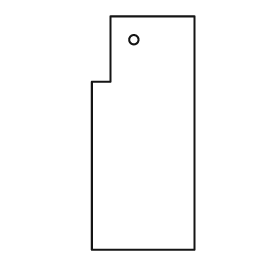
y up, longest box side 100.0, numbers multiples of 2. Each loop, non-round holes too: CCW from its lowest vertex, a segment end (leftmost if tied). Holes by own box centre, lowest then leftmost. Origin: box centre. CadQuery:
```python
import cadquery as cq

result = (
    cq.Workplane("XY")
    .moveTo(-22.0, -50.0)
    .lineTo(22.0, -50.0)
    .lineTo(22.0, 50.0)
    .lineTo(-14.0, 50.0)
    .lineTo(-14.0, 22.0)
    .lineTo(-22.0, 22.0)
    .close()
    .moveTo(-4.0, 40.0)
    .circle(2.0)
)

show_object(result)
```